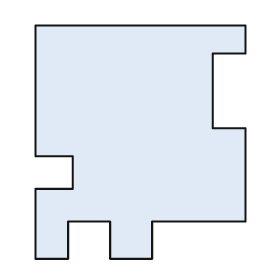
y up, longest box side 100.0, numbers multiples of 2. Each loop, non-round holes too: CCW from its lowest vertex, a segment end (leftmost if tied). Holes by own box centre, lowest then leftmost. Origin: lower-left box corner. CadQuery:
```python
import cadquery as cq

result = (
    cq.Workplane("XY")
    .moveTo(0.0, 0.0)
    .lineTo(14.0, 0.0)
    .lineTo(14.0, 16.0)
    .lineTo(32.0, 16.0)
    .lineTo(32.0, 0.0)
    .lineTo(50.0, 0.0)
    .lineTo(50.0, 16.0)
    .lineTo(90.0, 16.0)
    .lineTo(90.0, 56.0)
    .lineTo(76.0, 56.0)
    .lineTo(76.0, 88.0)
    .lineTo(90.0, 88.0)
    .lineTo(90.0, 100.0)
    .lineTo(0.0, 100.0)
    .lineTo(0.0, 44.0)
    .lineTo(16.0, 44.0)
    .lineTo(16.0, 30.0)
    .lineTo(0.0, 30.0)
    .close()
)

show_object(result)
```